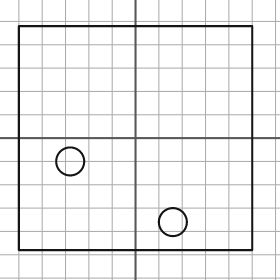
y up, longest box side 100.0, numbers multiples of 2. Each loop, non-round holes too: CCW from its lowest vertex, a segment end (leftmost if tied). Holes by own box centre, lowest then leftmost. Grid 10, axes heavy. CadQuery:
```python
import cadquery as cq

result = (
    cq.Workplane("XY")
    .moveTo(-50.0, -48.0)
    .lineTo(50.0, -48.0)
    .lineTo(50.0, 48.0)
    .lineTo(-50.0, 48.0)
    .close()
    .moveTo(16.0, -36.0)
    .circle(6.0)
    .moveTo(-28.0, -10.0)
    .circle(6.0)
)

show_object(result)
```